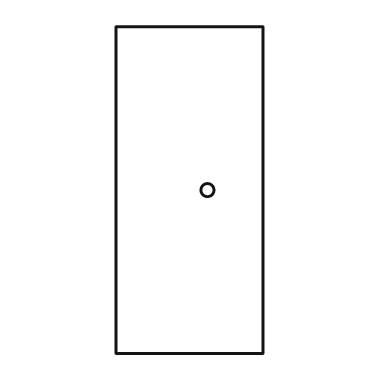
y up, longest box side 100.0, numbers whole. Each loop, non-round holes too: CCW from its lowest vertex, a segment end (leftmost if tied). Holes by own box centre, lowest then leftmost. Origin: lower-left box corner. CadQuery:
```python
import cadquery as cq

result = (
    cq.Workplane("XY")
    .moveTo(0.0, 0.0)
    .lineTo(45.0, 0.0)
    .lineTo(45.0, 100.0)
    .lineTo(0.0, 100.0)
    .close()
    .moveTo(28.0, 50.0)
    .circle(2.0)
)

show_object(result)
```